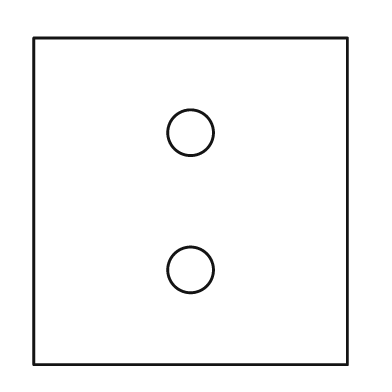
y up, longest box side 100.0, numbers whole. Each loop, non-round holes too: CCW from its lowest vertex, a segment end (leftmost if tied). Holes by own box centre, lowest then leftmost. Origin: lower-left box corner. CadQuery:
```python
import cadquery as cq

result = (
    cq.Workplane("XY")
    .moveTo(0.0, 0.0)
    .lineTo(96.0, 0.0)
    .lineTo(96.0, 100.0)
    .lineTo(0.0, 100.0)
    .close()
    .moveTo(48.0, 29.0)
    .circle(7.0)
    .moveTo(48.0, 71.0)
    .circle(7.0)
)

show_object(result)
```